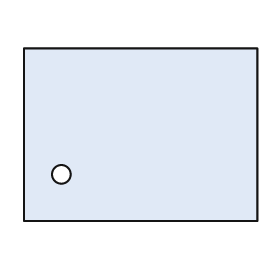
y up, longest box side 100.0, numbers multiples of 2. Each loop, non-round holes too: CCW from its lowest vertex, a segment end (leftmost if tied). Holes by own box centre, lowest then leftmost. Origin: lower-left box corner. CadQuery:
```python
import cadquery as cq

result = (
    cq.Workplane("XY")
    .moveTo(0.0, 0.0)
    .lineTo(100.0, 0.0)
    .lineTo(100.0, 74.0)
    .lineTo(0.0, 74.0)
    .close()
    .moveTo(16.0, 20.0)
    .circle(4.0)
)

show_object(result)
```